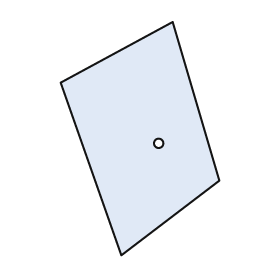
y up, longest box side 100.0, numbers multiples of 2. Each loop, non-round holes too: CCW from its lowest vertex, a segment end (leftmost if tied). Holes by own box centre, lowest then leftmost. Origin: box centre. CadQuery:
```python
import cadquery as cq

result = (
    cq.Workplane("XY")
    .moveTo(-8.0, -50.0)
    .lineTo(34.0, -18.0)
    .lineTo(14.0, 50.0)
    .lineTo(-34.0, 24.0)
    .close()
    .moveTo(8.0, -2.0)
    .circle(2.0)
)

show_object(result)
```